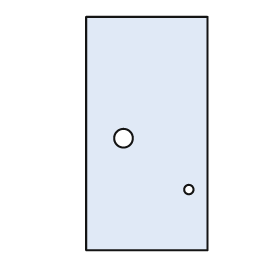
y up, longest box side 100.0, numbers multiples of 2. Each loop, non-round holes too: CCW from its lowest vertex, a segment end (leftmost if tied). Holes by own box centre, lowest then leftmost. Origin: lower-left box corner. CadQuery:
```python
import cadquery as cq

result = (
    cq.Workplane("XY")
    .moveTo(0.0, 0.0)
    .lineTo(52.0, 0.0)
    .lineTo(52.0, 100.0)
    .lineTo(0.0, 100.0)
    .close()
    .moveTo(44.0, 26.0)
    .circle(2.0)
    .moveTo(16.0, 48.0)
    .circle(4.0)
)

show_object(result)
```